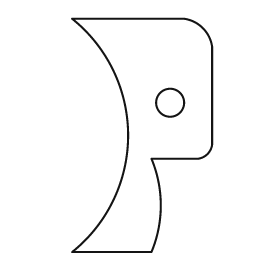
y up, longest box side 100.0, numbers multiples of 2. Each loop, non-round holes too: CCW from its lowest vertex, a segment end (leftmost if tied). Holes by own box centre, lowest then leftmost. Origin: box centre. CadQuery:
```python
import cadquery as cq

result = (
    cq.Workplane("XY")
    .moveTo(-30.0, -50.0)
    .lineTo(4.0, -50.0)
    .threePointArc((8.0, -30.0), (4.0, -10.0))
    .lineTo(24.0, -10.0)
    .threePointArc((28.0, -8.0), (30.0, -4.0))
    .lineTo(30.0, 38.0)
    .threePointArc((26.0, 46.0), (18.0, 50.0))
    .lineTo(-30.0, 50.0)
    .threePointArc((-6.0, 0.0), (-30.0, -50.0))
    .close()
    .moveTo(12.0, 14.0)
    .circle(6.0)
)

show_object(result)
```